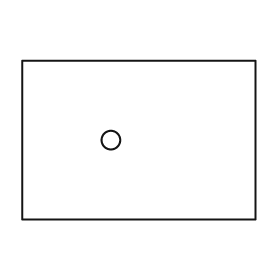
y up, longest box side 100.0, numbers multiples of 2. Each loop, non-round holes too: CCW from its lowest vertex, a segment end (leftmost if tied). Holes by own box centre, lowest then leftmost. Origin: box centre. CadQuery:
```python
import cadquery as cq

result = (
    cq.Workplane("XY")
    .moveTo(-50.0, -34.0)
    .lineTo(50.0, -34.0)
    .lineTo(50.0, 34.0)
    .lineTo(-50.0, 34.0)
    .close()
    .moveTo(-12.0, 0.0)
    .circle(4.0)
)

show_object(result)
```